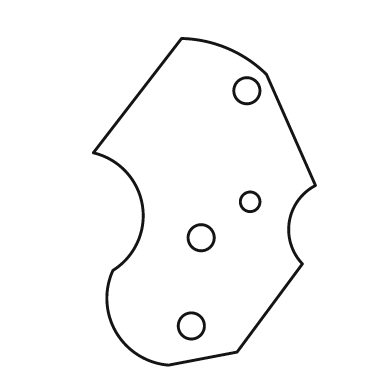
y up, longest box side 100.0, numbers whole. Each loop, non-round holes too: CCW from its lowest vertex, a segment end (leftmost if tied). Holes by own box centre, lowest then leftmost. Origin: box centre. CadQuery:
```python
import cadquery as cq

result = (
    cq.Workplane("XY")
    .moveTo(-11.0, -50.0)
    .lineTo(10.0, -46.0)
    .lineTo(30.0, -19.0)
    .threePointArc((26.0, -6.0), (34.0, 5.0))
    .lineTo(19.0, 39.0)
    .threePointArc((7.0, 47.0), (-7.0, 50.0))
    .lineTo(-34.0, 15.0)
    .threePointArc((-19.0, -1.0), (-28.0, -21.0))
    .threePointArc((-27.0, -40.0), (-11.0, -50.0))
    .close()
    .moveTo(-4.0, -38.0)
    .circle(4.0)
    .moveTo(-1.0, -11.0)
    .circle(4.0)
    .moveTo(14.0, 0.0)
    .circle(3.0)
    .moveTo(13.0, 34.0)
    .circle(4.0)
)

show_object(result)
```